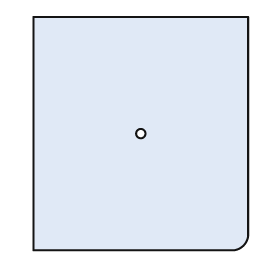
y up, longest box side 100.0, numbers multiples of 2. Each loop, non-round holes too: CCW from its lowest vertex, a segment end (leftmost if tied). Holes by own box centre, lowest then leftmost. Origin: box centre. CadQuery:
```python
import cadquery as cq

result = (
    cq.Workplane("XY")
    .moveTo(-46.0, -50.0)
    .lineTo(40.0, -50.0)
    .threePointArc((44.0, -48.0), (46.0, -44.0))
    .lineTo(46.0, 50.0)
    .lineTo(-46.0, 50.0)
    .close()
    .moveTo(0.0, 0.0)
    .circle(2.0)
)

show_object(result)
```